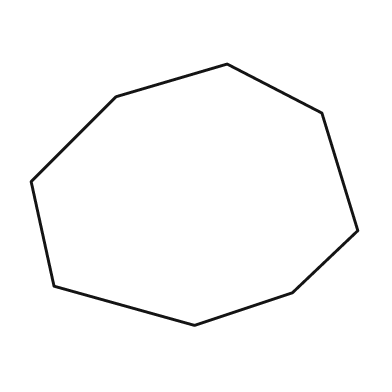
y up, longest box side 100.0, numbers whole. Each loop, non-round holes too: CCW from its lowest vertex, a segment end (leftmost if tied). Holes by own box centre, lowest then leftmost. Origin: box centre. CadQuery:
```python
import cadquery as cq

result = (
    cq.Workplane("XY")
    .moveTo(0.0, -40.0)
    .lineTo(30.0, -30.0)
    .lineTo(50.0, -11.0)
    .lineTo(39.0, 25.0)
    .lineTo(10.0, 40.0)
    .lineTo(-24.0, 30.0)
    .lineTo(-50.0, 4.0)
    .lineTo(-43.0, -28.0)
    .close()
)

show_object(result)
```